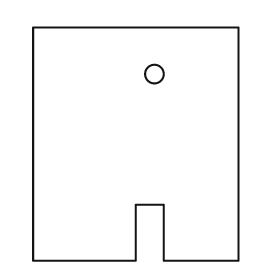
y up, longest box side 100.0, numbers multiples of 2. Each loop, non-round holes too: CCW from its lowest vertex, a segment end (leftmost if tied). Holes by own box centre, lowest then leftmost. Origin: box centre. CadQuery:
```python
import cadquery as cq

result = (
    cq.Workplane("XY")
    .moveTo(-44.0, -50.0)
    .lineTo(0.0, -50.0)
    .lineTo(0.0, -26.0)
    .lineTo(12.0, -26.0)
    .lineTo(12.0, -50.0)
    .lineTo(44.0, -50.0)
    .lineTo(44.0, 50.0)
    .lineTo(-44.0, 50.0)
    .close()
    .moveTo(8.0, 30.0)
    .circle(4.0)
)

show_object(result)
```